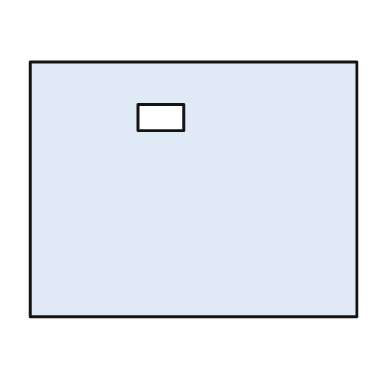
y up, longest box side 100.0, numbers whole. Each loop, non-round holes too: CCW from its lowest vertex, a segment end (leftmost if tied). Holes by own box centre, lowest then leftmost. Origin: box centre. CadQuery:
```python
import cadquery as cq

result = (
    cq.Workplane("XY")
    .moveTo(-50.0, -39.0)
    .lineTo(50.0, -39.0)
    .lineTo(50.0, 39.0)
    .lineTo(-50.0, 39.0)
    .close()
    .moveTo(-17.0, 18.0)
    .lineTo(-3.0, 18.0)
    .lineTo(-3.0, 26.0)
    .lineTo(-17.0, 26.0)
    .close()
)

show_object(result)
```